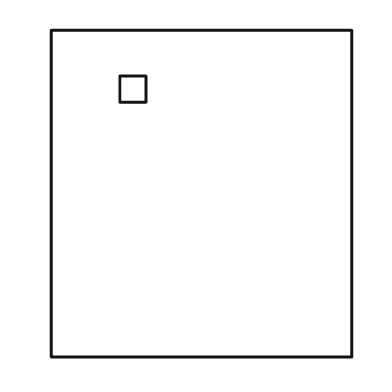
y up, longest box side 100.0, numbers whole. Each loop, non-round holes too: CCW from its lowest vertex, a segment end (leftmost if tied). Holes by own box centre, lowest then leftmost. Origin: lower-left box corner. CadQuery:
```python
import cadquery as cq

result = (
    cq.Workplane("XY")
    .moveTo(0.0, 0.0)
    .lineTo(92.0, 0.0)
    .lineTo(92.0, 100.0)
    .lineTo(0.0, 100.0)
    .close()
    .moveTo(21.0, 78.0)
    .lineTo(29.0, 78.0)
    .lineTo(29.0, 86.0)
    .lineTo(21.0, 86.0)
    .close()
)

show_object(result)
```